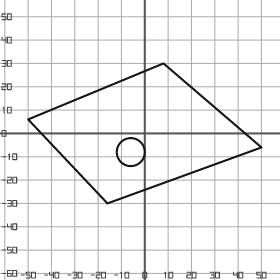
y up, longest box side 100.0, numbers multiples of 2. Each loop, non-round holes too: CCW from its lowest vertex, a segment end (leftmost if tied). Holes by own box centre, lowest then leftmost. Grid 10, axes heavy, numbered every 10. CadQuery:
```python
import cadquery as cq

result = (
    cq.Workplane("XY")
    .moveTo(-16.0, -30.0)
    .lineTo(50.0, -6.0)
    .lineTo(8.0, 30.0)
    .lineTo(-50.0, 6.0)
    .close()
    .moveTo(-6.0, -8.0)
    .circle(6.0)
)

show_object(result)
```